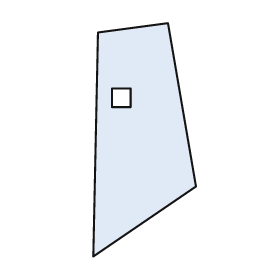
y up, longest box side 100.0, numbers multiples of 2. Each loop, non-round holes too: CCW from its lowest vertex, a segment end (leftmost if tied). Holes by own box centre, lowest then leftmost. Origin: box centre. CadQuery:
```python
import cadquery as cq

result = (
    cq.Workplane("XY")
    .moveTo(-22.0, -50.0)
    .lineTo(22.0, -20.0)
    .lineTo(10.0, 50.0)
    .lineTo(-20.0, 46.0)
    .close()
    .moveTo(-14.0, 14.0)
    .lineTo(-6.0, 14.0)
    .lineTo(-6.0, 22.0)
    .lineTo(-14.0, 22.0)
    .close()
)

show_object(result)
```